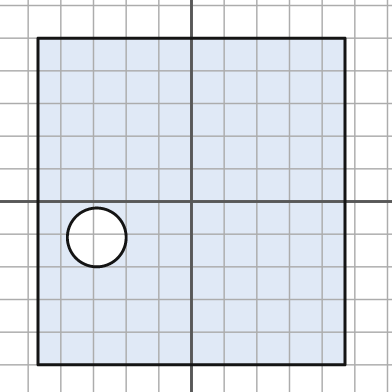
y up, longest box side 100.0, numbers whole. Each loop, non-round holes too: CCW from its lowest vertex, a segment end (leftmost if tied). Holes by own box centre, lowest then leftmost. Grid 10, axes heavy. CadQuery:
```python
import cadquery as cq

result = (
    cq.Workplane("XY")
    .moveTo(-47.0, -50.0)
    .lineTo(47.0, -50.0)
    .lineTo(47.0, 50.0)
    .lineTo(-47.0, 50.0)
    .close()
    .moveTo(-29.0, -11.0)
    .circle(9.0)
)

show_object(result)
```